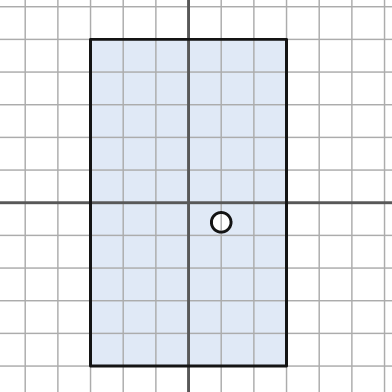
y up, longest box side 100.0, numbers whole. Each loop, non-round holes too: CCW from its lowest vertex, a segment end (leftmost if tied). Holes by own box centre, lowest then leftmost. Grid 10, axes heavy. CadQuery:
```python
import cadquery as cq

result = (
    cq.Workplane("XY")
    .moveTo(-30.0, -50.0)
    .lineTo(30.0, -50.0)
    .lineTo(30.0, 50.0)
    .lineTo(-30.0, 50.0)
    .close()
    .moveTo(10.0, -6.0)
    .circle(3.0)
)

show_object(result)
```